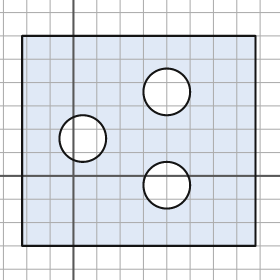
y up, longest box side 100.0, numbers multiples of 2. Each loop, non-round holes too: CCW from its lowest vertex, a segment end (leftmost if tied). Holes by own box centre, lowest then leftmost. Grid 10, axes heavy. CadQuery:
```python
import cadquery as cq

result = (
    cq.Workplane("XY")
    .moveTo(-22.0, -30.0)
    .lineTo(78.0, -30.0)
    .lineTo(78.0, 60.0)
    .lineTo(-22.0, 60.0)
    .close()
    .moveTo(40.0, -4.0)
    .circle(10.0)
    .moveTo(4.0, 16.0)
    .circle(10.0)
    .moveTo(40.0, 36.0)
    .circle(10.0)
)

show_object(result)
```